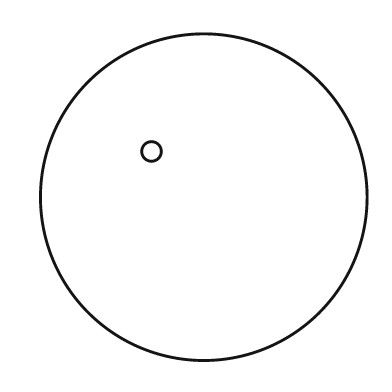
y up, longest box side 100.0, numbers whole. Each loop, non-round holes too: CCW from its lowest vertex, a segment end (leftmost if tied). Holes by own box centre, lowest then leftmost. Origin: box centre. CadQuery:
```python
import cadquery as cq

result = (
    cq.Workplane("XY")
    .moveTo(0.0, 0.0)
    .circle(50.0)
    .moveTo(-16.0, 14.0)
    .circle(3.0)
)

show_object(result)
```